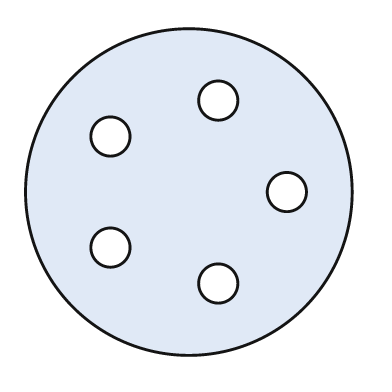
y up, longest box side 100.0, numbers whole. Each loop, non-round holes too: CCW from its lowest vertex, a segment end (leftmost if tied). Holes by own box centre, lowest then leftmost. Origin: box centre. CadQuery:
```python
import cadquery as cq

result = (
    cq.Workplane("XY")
    .moveTo(0.0, 0.0)
    .circle(50.0)
    .moveTo(9.0, -28.0)
    .circle(6.0)
    .moveTo(-24.0, -17.0)
    .circle(6.0)
    .moveTo(30.0, 0.0)
    .circle(6.0)
    .moveTo(-24.0, 17.0)
    .circle(6.0)
    .moveTo(9.0, 28.0)
    .circle(6.0)
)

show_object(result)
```